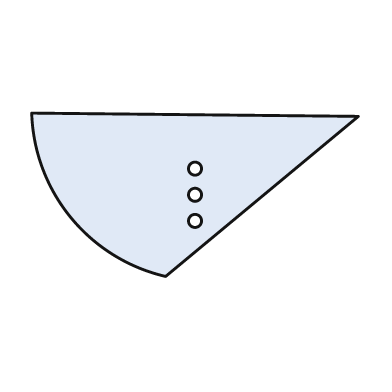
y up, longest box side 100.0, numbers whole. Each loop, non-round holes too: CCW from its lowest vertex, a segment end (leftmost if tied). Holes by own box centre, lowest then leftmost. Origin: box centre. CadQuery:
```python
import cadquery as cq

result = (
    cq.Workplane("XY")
    .moveTo(-9.0, -25.0)
    .lineTo(50.0, 24.0)
    .lineTo(-50.0, 25.0)
    .threePointArc((-38.0, -7.0), (-9.0, -25.0))
    .close()
    .moveTo(0.0, -8.0)
    .circle(2.0)
    .moveTo(0.0, 0.0)
    .circle(2.0)
    .moveTo(0.0, 8.0)
    .circle(2.0)
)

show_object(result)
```